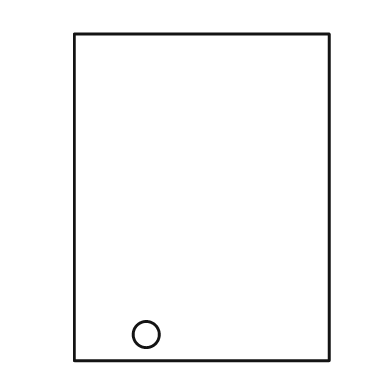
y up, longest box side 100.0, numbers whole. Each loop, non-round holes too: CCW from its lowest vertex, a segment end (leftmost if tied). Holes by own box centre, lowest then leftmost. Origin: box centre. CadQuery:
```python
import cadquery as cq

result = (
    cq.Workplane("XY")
    .moveTo(-39.0, -50.0)
    .lineTo(39.0, -50.0)
    .lineTo(39.0, 50.0)
    .lineTo(-39.0, 50.0)
    .close()
    .moveTo(-17.0, -42.0)
    .circle(4.0)
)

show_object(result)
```